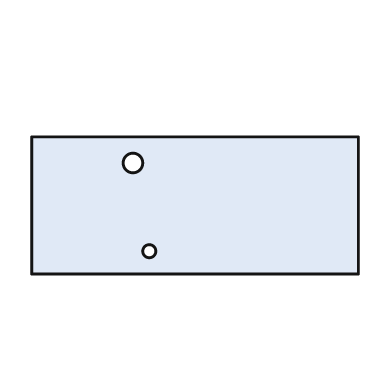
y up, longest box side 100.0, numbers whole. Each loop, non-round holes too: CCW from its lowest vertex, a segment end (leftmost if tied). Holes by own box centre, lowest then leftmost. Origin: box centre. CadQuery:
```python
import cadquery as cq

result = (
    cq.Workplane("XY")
    .moveTo(-50.0, -21.0)
    .lineTo(50.0, -21.0)
    .lineTo(50.0, 21.0)
    .lineTo(-50.0, 21.0)
    .close()
    .moveTo(-14.0, -14.0)
    .circle(2.0)
    .moveTo(-19.0, 13.0)
    .circle(3.0)
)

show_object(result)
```